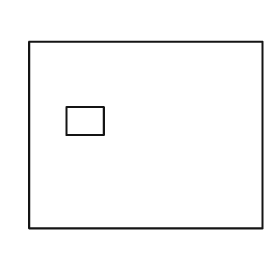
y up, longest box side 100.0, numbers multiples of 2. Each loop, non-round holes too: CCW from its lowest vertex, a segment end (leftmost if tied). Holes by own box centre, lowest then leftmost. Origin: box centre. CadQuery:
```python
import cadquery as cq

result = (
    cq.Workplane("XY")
    .moveTo(-50.0, -40.0)
    .lineTo(50.0, -40.0)
    .lineTo(50.0, 40.0)
    .lineTo(-50.0, 40.0)
    .close()
    .moveTo(-34.0, 0.0)
    .lineTo(-18.0, 0.0)
    .lineTo(-18.0, 12.0)
    .lineTo(-34.0, 12.0)
    .close()
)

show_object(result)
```